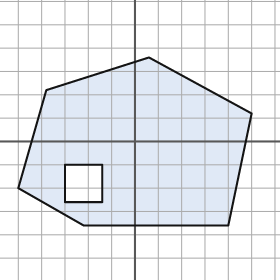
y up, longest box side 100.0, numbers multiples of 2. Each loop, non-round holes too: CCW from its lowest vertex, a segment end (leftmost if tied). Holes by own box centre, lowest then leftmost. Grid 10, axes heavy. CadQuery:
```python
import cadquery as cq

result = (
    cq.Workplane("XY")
    .moveTo(-22.0, -36.0)
    .lineTo(40.0, -36.0)
    .lineTo(50.0, 12.0)
    .lineTo(6.0, 36.0)
    .lineTo(-38.0, 22.0)
    .lineTo(-50.0, -20.0)
    .close()
    .moveTo(-30.0, -26.0)
    .lineTo(-14.0, -26.0)
    .lineTo(-14.0, -10.0)
    .lineTo(-30.0, -10.0)
    .close()
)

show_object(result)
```